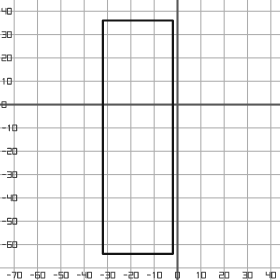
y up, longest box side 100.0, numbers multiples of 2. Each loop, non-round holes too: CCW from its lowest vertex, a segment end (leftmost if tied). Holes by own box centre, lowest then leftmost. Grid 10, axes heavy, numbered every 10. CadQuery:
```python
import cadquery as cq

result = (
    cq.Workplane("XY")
    .moveTo(-32.0, -64.0)
    .lineTo(-2.0, -64.0)
    .lineTo(-2.0, 36.0)
    .lineTo(-32.0, 36.0)
    .close()
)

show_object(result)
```